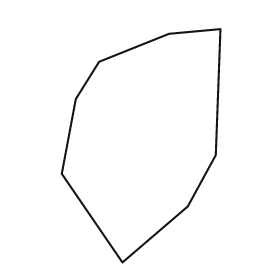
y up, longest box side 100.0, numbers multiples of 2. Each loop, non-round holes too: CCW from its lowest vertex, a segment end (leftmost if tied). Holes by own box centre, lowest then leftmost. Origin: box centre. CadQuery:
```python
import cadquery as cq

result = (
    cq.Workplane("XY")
    .moveTo(-8.0, -50.0)
    .lineTo(20.0, -26.0)
    .lineTo(32.0, -4.0)
    .lineTo(34.0, 50.0)
    .lineTo(12.0, 48.0)
    .lineTo(-18.0, 36.0)
    .lineTo(-28.0, 20.0)
    .lineTo(-34.0, -12.0)
    .close()
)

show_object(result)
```